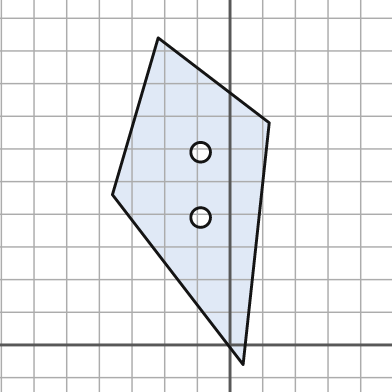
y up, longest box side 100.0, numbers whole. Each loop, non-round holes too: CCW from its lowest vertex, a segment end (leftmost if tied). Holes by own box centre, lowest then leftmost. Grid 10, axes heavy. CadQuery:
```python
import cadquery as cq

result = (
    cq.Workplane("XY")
    .moveTo(4.0, -6.0)
    .lineTo(12.0, 68.0)
    .lineTo(-22.0, 94.0)
    .lineTo(-36.0, 46.0)
    .close()
    .moveTo(-9.0, 39.0)
    .circle(3.0)
    .moveTo(-9.0, 59.0)
    .circle(3.0)
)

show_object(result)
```